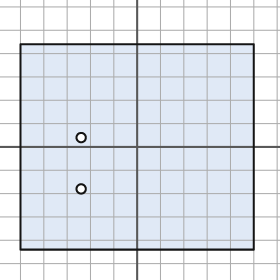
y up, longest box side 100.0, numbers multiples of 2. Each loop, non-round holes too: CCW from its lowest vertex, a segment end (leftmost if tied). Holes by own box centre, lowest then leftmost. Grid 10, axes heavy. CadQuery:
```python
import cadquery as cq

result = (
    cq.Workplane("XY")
    .moveTo(-50.0, -44.0)
    .lineTo(50.0, -44.0)
    .lineTo(50.0, 44.0)
    .lineTo(-50.0, 44.0)
    .close()
    .moveTo(-24.0, -18.0)
    .circle(2.0)
    .moveTo(-24.0, 4.0)
    .circle(2.0)
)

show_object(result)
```